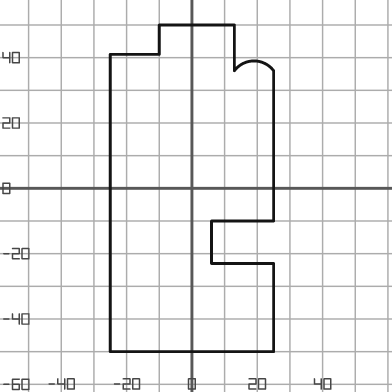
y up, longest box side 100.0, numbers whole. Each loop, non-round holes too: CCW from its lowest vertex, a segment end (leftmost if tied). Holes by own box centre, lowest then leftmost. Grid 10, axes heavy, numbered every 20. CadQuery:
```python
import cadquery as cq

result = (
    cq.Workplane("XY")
    .moveTo(-25.0, -50.0)
    .lineTo(25.0, -50.0)
    .lineTo(25.0, -23.0)
    .lineTo(6.0, -23.0)
    .lineTo(6.0, -10.0)
    .lineTo(25.0, -10.0)
    .lineTo(25.0, 36.0)
    .threePointArc((19.0, 39.0), (13.0, 36.0))
    .lineTo(13.0, 50.0)
    .lineTo(-10.0, 50.0)
    .lineTo(-10.0, 41.0)
    .lineTo(-25.0, 41.0)
    .close()
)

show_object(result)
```